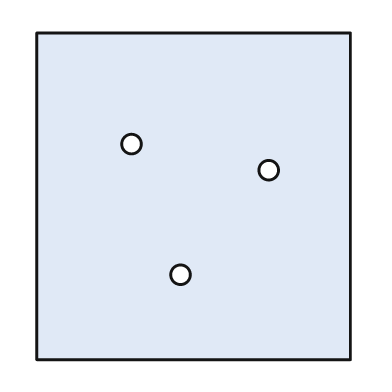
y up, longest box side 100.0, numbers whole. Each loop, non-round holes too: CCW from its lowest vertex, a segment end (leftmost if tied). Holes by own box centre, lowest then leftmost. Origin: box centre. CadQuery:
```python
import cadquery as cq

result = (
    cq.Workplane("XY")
    .moveTo(-48.0, -50.0)
    .lineTo(48.0, -50.0)
    .lineTo(48.0, 50.0)
    .lineTo(-48.0, 50.0)
    .close()
    .moveTo(-4.0, -24.0)
    .circle(3.0)
    .moveTo(23.0, 8.0)
    .circle(3.0)
    .moveTo(-19.0, 16.0)
    .circle(3.0)
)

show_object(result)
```